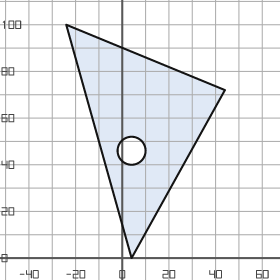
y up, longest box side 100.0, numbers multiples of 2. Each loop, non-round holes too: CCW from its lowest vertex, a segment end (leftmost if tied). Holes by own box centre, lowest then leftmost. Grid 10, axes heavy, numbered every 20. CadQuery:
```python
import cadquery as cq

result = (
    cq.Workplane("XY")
    .moveTo(4.0, 0.0)
    .lineTo(44.0, 72.0)
    .lineTo(-24.0, 100.0)
    .close()
    .moveTo(4.0, 46.0)
    .circle(6.0)
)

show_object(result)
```